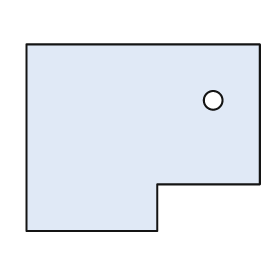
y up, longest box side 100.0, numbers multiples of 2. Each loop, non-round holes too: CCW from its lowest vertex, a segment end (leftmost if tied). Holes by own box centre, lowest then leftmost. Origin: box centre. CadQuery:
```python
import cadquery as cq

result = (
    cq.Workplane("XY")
    .moveTo(-50.0, -40.0)
    .lineTo(6.0, -40.0)
    .lineTo(6.0, -20.0)
    .lineTo(50.0, -20.0)
    .lineTo(50.0, 40.0)
    .lineTo(-50.0, 40.0)
    .close()
    .moveTo(30.0, 16.0)
    .circle(4.0)
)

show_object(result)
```